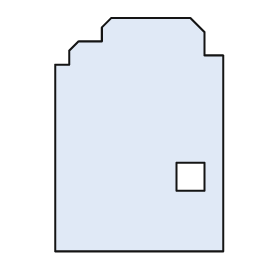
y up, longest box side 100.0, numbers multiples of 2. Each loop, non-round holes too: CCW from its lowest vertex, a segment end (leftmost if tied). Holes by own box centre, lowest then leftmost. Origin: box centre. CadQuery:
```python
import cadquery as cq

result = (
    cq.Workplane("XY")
    .moveTo(-36.0, -50.0)
    .lineTo(36.0, -50.0)
    .lineTo(36.0, 34.0)
    .lineTo(28.0, 34.0)
    .lineTo(28.0, 44.0)
    .lineTo(22.0, 50.0)
    .lineTo(-12.0, 50.0)
    .lineTo(-16.0, 46.0)
    .lineTo(-16.0, 40.0)
    .lineTo(-26.0, 40.0)
    .lineTo(-30.0, 36.0)
    .lineTo(-30.0, 30.0)
    .lineTo(-36.0, 30.0)
    .close()
    .moveTo(16.0, -24.0)
    .lineTo(28.0, -24.0)
    .lineTo(28.0, -12.0)
    .lineTo(16.0, -12.0)
    .close()
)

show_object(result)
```